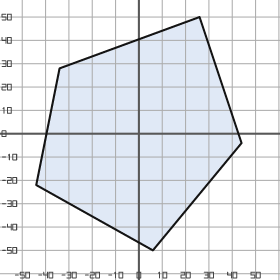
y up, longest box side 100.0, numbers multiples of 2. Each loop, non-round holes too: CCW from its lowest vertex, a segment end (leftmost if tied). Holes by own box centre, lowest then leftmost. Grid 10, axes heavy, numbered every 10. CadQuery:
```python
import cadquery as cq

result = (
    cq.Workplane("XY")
    .moveTo(6.0, -50.0)
    .lineTo(44.0, -4.0)
    .lineTo(26.0, 50.0)
    .lineTo(-34.0, 28.0)
    .lineTo(-44.0, -22.0)
    .close()
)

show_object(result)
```